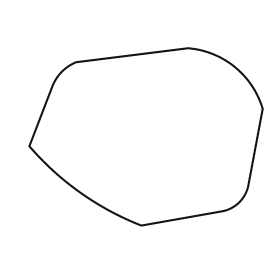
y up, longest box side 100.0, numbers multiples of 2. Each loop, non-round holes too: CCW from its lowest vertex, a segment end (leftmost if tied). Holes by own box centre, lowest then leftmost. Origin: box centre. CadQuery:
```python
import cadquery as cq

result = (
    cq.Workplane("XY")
    .moveTo(-2.0, -38.0)
    .lineTo(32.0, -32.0)
    .threePointArc((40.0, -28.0), (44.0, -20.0))
    .lineTo(50.0, 12.0)
    .threePointArc((38.0, 30.0), (18.0, 38.0))
    .lineTo(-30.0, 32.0)
    .threePointArc((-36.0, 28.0), (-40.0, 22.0))
    .lineTo(-50.0, -4.0)
    .threePointArc((-28.0, -24.0), (-2.0, -38.0))
    .close()
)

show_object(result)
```